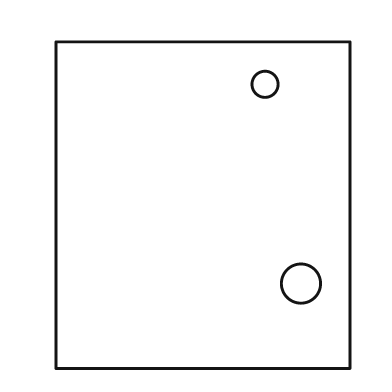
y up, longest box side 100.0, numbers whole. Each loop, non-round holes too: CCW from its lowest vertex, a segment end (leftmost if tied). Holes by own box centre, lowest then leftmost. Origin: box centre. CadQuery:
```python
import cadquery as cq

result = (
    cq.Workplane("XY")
    .moveTo(-45.0, -50.0)
    .lineTo(45.0, -50.0)
    .lineTo(45.0, 50.0)
    .lineTo(-45.0, 50.0)
    .close()
    .moveTo(30.0, -24.0)
    .circle(6.0)
    .moveTo(19.0, 37.0)
    .circle(4.0)
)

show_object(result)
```